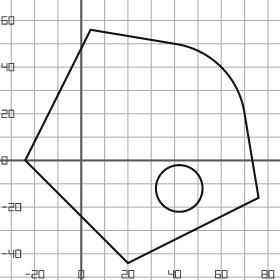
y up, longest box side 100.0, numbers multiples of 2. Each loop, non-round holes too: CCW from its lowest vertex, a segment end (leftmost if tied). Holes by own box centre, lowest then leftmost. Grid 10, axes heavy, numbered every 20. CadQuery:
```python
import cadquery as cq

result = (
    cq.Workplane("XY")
    .moveTo(20.0, -44.0)
    .lineTo(76.0, -16.0)
    .lineTo(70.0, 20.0)
    .threePointArc((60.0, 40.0), (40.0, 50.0))
    .lineTo(4.0, 56.0)
    .lineTo(-24.0, 0.0)
    .close()
    .moveTo(42.0, -12.0)
    .circle(10.0)
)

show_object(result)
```